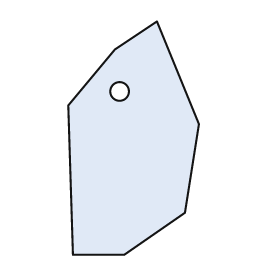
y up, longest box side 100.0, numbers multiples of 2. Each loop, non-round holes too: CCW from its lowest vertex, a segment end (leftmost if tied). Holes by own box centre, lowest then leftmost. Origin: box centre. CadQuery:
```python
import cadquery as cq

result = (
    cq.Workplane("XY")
    .moveTo(-26.0, -50.0)
    .lineTo(-4.0, -50.0)
    .lineTo(22.0, -32.0)
    .lineTo(28.0, 6.0)
    .lineTo(10.0, 50.0)
    .lineTo(-8.0, 38.0)
    .lineTo(-28.0, 14.0)
    .close()
    .moveTo(-6.0, 20.0)
    .circle(4.0)
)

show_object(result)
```